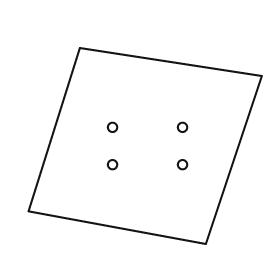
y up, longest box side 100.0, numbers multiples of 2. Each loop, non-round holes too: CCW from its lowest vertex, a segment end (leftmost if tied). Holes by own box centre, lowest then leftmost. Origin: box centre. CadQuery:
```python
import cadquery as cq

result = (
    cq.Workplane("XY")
    .moveTo(26.0, -42.0)
    .lineTo(50.0, 30.0)
    .lineTo(-28.0, 42.0)
    .lineTo(-50.0, -28.0)
    .close()
    .moveTo(-14.0, -8.0)
    .circle(2.0)
    .moveTo(16.0, -8.0)
    .circle(2.0)
    .moveTo(-14.0, 8.0)
    .circle(2.0)
    .moveTo(16.0, 8.0)
    .circle(2.0)
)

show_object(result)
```